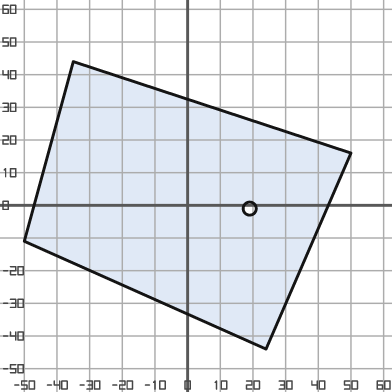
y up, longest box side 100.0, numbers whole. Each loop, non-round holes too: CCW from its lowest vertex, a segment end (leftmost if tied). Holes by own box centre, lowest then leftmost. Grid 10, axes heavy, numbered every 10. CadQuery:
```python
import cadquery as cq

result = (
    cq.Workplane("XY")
    .moveTo(24.0, -44.0)
    .lineTo(50.0, 16.0)
    .lineTo(-35.0, 44.0)
    .lineTo(-50.0, -11.0)
    .close()
    .moveTo(19.0, -1.0)
    .circle(2.0)
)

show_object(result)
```